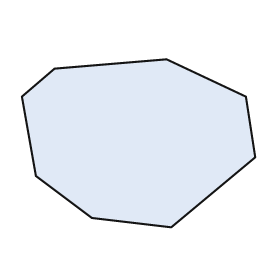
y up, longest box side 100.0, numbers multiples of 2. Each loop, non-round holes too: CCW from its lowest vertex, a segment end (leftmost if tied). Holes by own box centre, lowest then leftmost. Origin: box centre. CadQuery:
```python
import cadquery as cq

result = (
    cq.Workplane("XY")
    .moveTo(14.0, -36.0)
    .lineTo(50.0, -6.0)
    .lineTo(46.0, 20.0)
    .lineTo(12.0, 36.0)
    .lineTo(-36.0, 32.0)
    .lineTo(-50.0, 20.0)
    .lineTo(-44.0, -14.0)
    .lineTo(-20.0, -32.0)
    .close()
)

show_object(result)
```